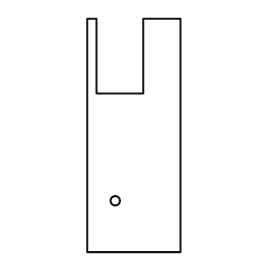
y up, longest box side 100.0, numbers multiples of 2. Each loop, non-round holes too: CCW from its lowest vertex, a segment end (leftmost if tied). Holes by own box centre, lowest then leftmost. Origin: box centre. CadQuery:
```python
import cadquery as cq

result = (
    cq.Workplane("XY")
    .moveTo(-20.0, -50.0)
    .lineTo(20.0, -50.0)
    .lineTo(20.0, 50.0)
    .lineTo(4.0, 50.0)
    .lineTo(4.0, 18.0)
    .lineTo(-16.0, 18.0)
    .lineTo(-16.0, 50.0)
    .lineTo(-20.0, 50.0)
    .close()
    .moveTo(-8.0, -28.0)
    .circle(2.0)
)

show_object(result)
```